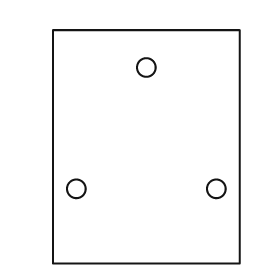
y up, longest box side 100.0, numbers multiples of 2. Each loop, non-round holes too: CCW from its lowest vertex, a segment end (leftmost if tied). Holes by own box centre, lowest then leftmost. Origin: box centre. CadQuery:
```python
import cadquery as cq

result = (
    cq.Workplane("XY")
    .moveTo(-40.0, -50.0)
    .lineTo(40.0, -50.0)
    .lineTo(40.0, 50.0)
    .lineTo(-40.0, 50.0)
    .close()
    .moveTo(-30.0, -18.0)
    .circle(4.0)
    .moveTo(30.0, -18.0)
    .circle(4.0)
    .moveTo(0.0, 34.0)
    .circle(4.0)
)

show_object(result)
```